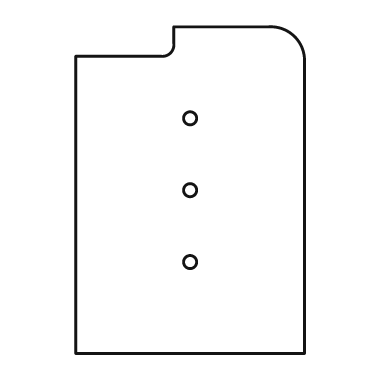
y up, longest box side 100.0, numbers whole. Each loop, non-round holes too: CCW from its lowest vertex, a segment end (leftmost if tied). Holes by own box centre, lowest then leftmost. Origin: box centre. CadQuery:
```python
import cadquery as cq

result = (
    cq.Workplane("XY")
    .moveTo(-35.0, -50.0)
    .lineTo(35.0, -50.0)
    .lineTo(35.0, 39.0)
    .threePointArc((32.0, 47.0), (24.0, 50.0))
    .lineTo(-5.0, 50.0)
    .lineTo(-5.0, 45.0)
    .threePointArc((-6.0, 42.0), (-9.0, 41.0))
    .lineTo(-35.0, 41.0)
    .close()
    .moveTo(0.0, -22.0)
    .circle(2.0)
    .moveTo(0.0, 0.0)
    .circle(2.0)
    .moveTo(0.0, 22.0)
    .circle(2.0)
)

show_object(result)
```